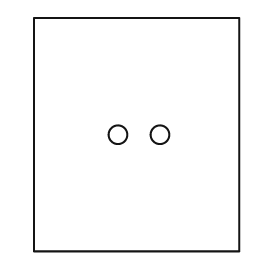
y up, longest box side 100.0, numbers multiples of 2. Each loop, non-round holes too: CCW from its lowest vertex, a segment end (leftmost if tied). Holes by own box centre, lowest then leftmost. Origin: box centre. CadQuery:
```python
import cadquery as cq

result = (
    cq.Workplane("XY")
    .moveTo(-44.0, -50.0)
    .lineTo(44.0, -50.0)
    .lineTo(44.0, 50.0)
    .lineTo(-44.0, 50.0)
    .close()
    .moveTo(-8.0, 0.0)
    .circle(4.0)
    .moveTo(10.0, 0.0)
    .circle(4.0)
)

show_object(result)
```